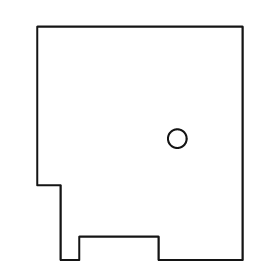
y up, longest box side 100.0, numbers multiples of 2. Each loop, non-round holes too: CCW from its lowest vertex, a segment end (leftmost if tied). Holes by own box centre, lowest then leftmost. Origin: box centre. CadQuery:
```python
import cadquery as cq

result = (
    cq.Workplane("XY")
    .moveTo(-34.0, -50.0)
    .lineTo(-26.0, -50.0)
    .lineTo(-26.0, -40.0)
    .lineTo(8.0, -40.0)
    .lineTo(8.0, -50.0)
    .lineTo(44.0, -50.0)
    .lineTo(44.0, 50.0)
    .lineTo(-44.0, 50.0)
    .lineTo(-44.0, -18.0)
    .lineTo(-34.0, -18.0)
    .close()
    .moveTo(16.0, 2.0)
    .circle(4.0)
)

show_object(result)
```